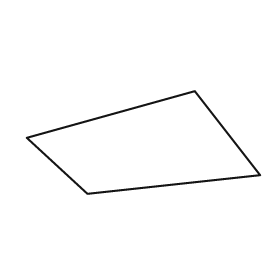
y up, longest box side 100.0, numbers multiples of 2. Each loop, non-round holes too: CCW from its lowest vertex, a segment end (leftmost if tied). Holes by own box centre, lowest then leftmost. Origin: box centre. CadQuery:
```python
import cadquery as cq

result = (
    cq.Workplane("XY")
    .moveTo(-24.0, -22.0)
    .lineTo(50.0, -14.0)
    .lineTo(22.0, 22.0)
    .lineTo(-50.0, 2.0)
    .close()
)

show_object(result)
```